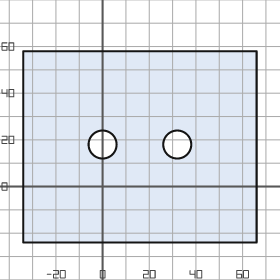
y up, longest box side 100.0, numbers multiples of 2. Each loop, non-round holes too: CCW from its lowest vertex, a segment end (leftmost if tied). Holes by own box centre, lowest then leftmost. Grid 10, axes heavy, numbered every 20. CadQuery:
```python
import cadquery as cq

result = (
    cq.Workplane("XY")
    .moveTo(-34.0, -24.0)
    .lineTo(66.0, -24.0)
    .lineTo(66.0, 58.0)
    .lineTo(-34.0, 58.0)
    .close()
    .moveTo(0.0, 18.0)
    .circle(6.0)
    .moveTo(32.0, 18.0)
    .circle(6.0)
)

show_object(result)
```